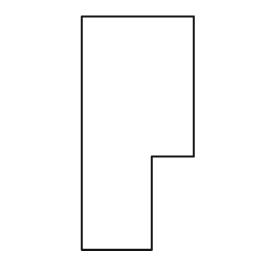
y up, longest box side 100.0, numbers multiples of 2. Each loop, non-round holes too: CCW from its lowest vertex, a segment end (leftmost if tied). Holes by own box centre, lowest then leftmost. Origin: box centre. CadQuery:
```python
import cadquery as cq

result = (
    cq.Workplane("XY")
    .moveTo(-24.0, -50.0)
    .lineTo(6.0, -50.0)
    .lineTo(6.0, -10.0)
    .lineTo(24.0, -10.0)
    .lineTo(24.0, 50.0)
    .lineTo(-24.0, 50.0)
    .close()
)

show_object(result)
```